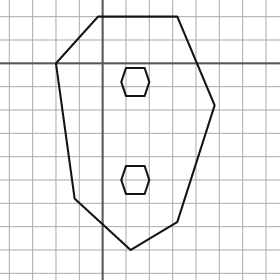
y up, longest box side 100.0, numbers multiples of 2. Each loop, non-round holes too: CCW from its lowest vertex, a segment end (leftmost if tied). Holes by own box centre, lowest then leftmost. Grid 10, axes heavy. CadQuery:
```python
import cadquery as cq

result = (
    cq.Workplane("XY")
    .moveTo(12.0, -80.0)
    .lineTo(32.0, -68.0)
    .lineTo(48.0, -18.0)
    .lineTo(32.0, 20.0)
    .lineTo(-2.0, 20.0)
    .lineTo(-20.0, 0.0)
    .lineTo(-12.0, -58.0)
    .close()
    .moveTo(10.0, -56.0)
    .lineTo(18.0, -56.0)
    .lineTo(20.0, -50.0)
    .lineTo(18.0, -44.0)
    .lineTo(10.0, -44.0)
    .lineTo(8.0, -50.0)
    .close()
    .moveTo(10.0, -14.0)
    .lineTo(18.0, -14.0)
    .lineTo(20.0, -8.0)
    .lineTo(18.0, -2.0)
    .lineTo(10.0, -2.0)
    .lineTo(8.0, -8.0)
    .close()
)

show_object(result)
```